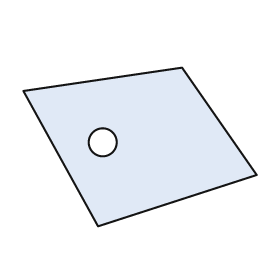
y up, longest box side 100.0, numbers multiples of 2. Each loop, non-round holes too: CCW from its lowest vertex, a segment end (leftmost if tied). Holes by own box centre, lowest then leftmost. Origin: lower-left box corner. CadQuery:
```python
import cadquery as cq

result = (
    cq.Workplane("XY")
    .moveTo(32.0, 0.0)
    .lineTo(100.0, 22.0)
    .lineTo(68.0, 68.0)
    .lineTo(0.0, 58.0)
    .close()
    .moveTo(34.0, 36.0)
    .circle(6.0)
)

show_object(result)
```